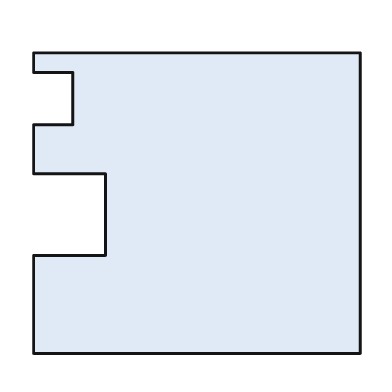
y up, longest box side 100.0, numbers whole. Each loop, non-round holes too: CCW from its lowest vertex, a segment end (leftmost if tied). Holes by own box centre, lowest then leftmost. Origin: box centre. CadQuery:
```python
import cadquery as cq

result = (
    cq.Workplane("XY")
    .moveTo(-50.0, -46.0)
    .lineTo(50.0, -46.0)
    .lineTo(50.0, 46.0)
    .lineTo(-50.0, 46.0)
    .lineTo(-50.0, 40.0)
    .lineTo(-38.0, 40.0)
    .lineTo(-38.0, 24.0)
    .lineTo(-50.0, 24.0)
    .lineTo(-50.0, 9.0)
    .lineTo(-28.0, 9.0)
    .lineTo(-28.0, -16.0)
    .lineTo(-50.0, -16.0)
    .close()
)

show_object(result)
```